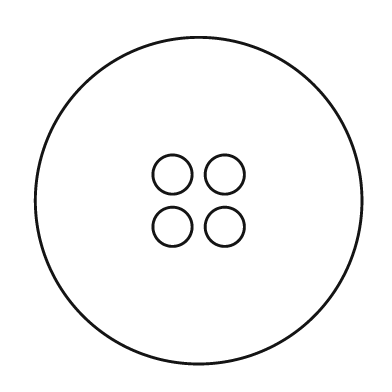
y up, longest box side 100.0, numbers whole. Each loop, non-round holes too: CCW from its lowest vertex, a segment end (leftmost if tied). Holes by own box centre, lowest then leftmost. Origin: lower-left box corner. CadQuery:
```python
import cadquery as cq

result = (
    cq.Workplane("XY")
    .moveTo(50.0, 50.0)
    .circle(50.0)
    .moveTo(42.0, 42.0)
    .circle(6.0)
    .moveTo(58.0, 42.0)
    .circle(6.0)
    .moveTo(42.0, 58.0)
    .circle(6.0)
    .moveTo(58.0, 58.0)
    .circle(6.0)
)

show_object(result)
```